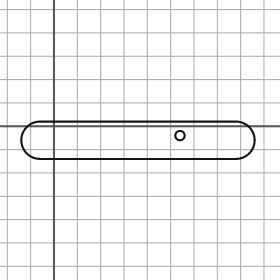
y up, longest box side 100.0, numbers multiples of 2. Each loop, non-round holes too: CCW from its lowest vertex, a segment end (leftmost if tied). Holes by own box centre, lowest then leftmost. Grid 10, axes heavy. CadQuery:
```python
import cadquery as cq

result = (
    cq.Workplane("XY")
    .moveTo(-6.0, -14.0)
    .lineTo(78.0, -14.0)
    .threePointArc((86.0, -6.0), (78.0, 2.0))
    .lineTo(-6.0, 2.0)
    .threePointArc((-14.0, -6.0), (-6.0, -14.0))
    .close()
    .moveTo(54.0, -4.0)
    .circle(2.0)
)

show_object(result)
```